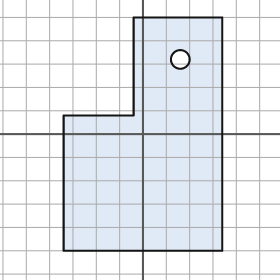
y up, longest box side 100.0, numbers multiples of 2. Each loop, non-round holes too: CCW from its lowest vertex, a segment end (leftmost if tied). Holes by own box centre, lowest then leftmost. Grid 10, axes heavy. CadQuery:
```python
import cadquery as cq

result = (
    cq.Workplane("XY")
    .moveTo(-34.0, -50.0)
    .lineTo(34.0, -50.0)
    .lineTo(34.0, 50.0)
    .lineTo(-4.0, 50.0)
    .lineTo(-4.0, 8.0)
    .lineTo(-34.0, 8.0)
    .close()
    .moveTo(16.0, 32.0)
    .circle(4.0)
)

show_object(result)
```